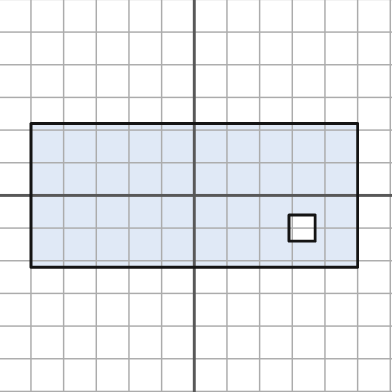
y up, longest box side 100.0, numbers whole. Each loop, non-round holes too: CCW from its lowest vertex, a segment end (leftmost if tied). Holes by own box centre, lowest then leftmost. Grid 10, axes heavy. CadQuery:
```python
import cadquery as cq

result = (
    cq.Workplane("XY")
    .moveTo(-50.0, -22.0)
    .lineTo(50.0, -22.0)
    .lineTo(50.0, 22.0)
    .lineTo(-50.0, 22.0)
    .close()
    .moveTo(29.0, -14.0)
    .lineTo(37.0, -14.0)
    .lineTo(37.0, -6.0)
    .lineTo(29.0, -6.0)
    .close()
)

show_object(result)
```